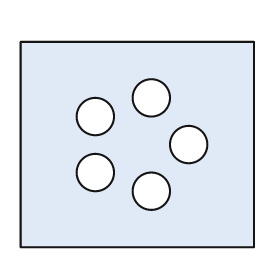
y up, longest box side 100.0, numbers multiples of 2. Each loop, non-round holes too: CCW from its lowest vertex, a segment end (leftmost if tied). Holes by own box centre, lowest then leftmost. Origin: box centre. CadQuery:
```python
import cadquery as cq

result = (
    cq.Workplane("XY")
    .moveTo(-50.0, -44.0)
    .lineTo(50.0, -44.0)
    .lineTo(50.0, 44.0)
    .lineTo(-50.0, 44.0)
    .close()
    .moveTo(6.0, -20.0)
    .circle(8.0)
    .moveTo(-18.0, -12.0)
    .circle(8.0)
    .moveTo(22.0, 0.0)
    .circle(8.0)
    .moveTo(-18.0, 12.0)
    .circle(8.0)
    .moveTo(6.0, 20.0)
    .circle(8.0)
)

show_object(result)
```